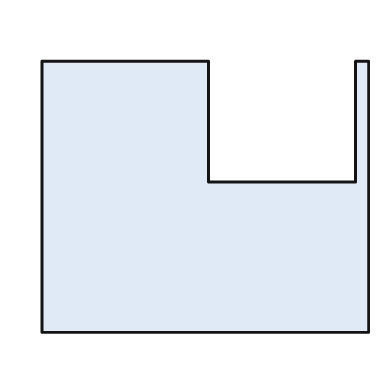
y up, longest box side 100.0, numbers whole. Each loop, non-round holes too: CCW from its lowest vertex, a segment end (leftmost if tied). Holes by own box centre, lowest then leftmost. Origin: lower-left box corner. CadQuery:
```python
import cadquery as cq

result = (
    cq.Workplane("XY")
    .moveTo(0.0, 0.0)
    .lineTo(100.0, 0.0)
    .lineTo(100.0, 83.0)
    .lineTo(96.0, 83.0)
    .lineTo(96.0, 46.0)
    .lineTo(51.0, 46.0)
    .lineTo(51.0, 83.0)
    .lineTo(0.0, 83.0)
    .close()
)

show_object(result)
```